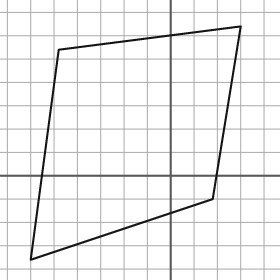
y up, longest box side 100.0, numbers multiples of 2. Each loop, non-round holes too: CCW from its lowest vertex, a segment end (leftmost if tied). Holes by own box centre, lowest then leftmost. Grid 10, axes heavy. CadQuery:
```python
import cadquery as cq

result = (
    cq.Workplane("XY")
    .moveTo(-60.0, -36.0)
    .lineTo(18.0, -10.0)
    .lineTo(30.0, 64.0)
    .lineTo(-48.0, 54.0)
    .close()
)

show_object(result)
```